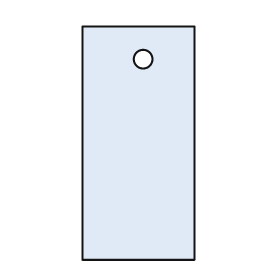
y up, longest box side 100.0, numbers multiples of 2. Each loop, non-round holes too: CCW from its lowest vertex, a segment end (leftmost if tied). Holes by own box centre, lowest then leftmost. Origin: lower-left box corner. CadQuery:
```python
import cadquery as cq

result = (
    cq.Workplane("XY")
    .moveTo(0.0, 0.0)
    .lineTo(48.0, 0.0)
    .lineTo(48.0, 100.0)
    .lineTo(0.0, 100.0)
    .close()
    .moveTo(26.0, 86.0)
    .circle(4.0)
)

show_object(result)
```